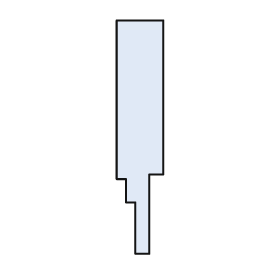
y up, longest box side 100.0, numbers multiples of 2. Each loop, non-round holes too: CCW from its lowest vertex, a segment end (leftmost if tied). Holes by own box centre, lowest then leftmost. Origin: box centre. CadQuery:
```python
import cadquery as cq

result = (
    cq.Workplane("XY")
    .moveTo(-2.0, -50.0)
    .lineTo(4.0, -50.0)
    .lineTo(4.0, -16.0)
    .lineTo(10.0, -16.0)
    .lineTo(10.0, 50.0)
    .lineTo(-10.0, 50.0)
    .lineTo(-10.0, -18.0)
    .lineTo(-6.0, -18.0)
    .lineTo(-6.0, -28.0)
    .lineTo(-2.0, -28.0)
    .close()
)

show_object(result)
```